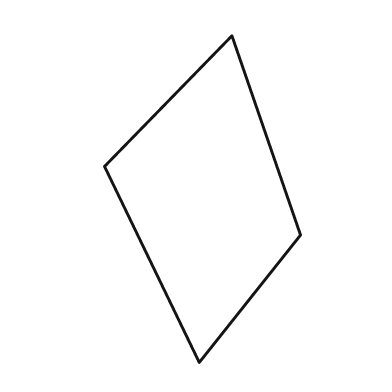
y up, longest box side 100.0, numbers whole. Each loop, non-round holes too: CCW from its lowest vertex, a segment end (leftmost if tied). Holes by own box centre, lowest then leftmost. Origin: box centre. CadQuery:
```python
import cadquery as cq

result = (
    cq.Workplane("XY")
    .moveTo(-1.0, -50.0)
    .lineTo(30.0, -11.0)
    .lineTo(9.0, 50.0)
    .lineTo(-30.0, 10.0)
    .close()
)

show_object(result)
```